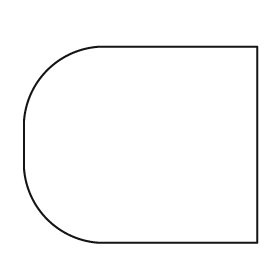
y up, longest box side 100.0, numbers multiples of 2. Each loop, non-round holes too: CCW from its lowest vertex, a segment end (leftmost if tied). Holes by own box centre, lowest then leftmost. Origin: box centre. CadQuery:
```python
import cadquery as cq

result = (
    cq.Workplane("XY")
    .moveTo(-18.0, -42.0)
    .lineTo(50.0, -42.0)
    .lineTo(50.0, 42.0)
    .lineTo(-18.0, 42.0)
    .threePointArc((-40.0, 32.0), (-50.0, 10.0))
    .lineTo(-50.0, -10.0)
    .threePointArc((-40.0, -32.0), (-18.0, -42.0))
    .close()
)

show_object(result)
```